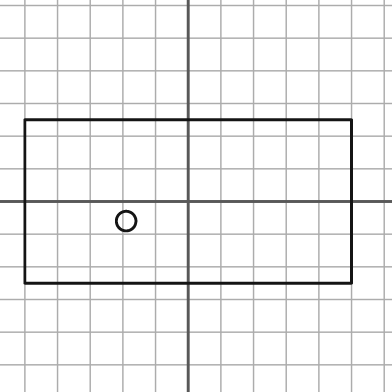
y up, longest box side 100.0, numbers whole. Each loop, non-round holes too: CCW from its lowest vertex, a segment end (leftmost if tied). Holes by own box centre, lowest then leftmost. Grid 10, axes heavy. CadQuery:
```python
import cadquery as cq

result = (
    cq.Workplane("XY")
    .moveTo(-50.0, -25.0)
    .lineTo(50.0, -25.0)
    .lineTo(50.0, 25.0)
    .lineTo(-50.0, 25.0)
    .close()
    .moveTo(-19.0, -6.0)
    .circle(3.0)
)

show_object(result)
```